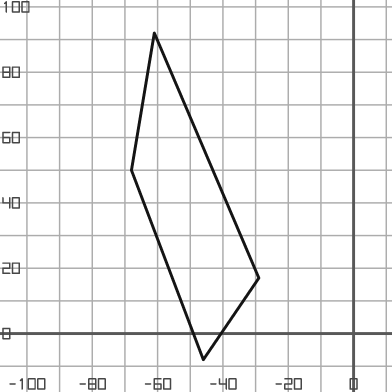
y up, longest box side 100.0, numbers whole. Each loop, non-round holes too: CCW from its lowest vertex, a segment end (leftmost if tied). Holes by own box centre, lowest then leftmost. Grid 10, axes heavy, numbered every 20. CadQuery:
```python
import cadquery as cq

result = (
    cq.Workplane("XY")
    .moveTo(-46.0, -8.0)
    .lineTo(-29.0, 17.0)
    .lineTo(-61.0, 92.0)
    .lineTo(-68.0, 50.0)
    .close()
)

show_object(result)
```